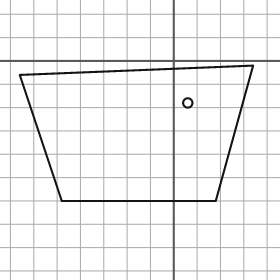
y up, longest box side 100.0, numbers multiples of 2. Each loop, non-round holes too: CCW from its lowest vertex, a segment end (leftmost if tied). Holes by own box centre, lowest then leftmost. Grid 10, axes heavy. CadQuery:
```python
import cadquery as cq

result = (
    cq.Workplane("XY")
    .moveTo(-48.0, -60.0)
    .lineTo(18.0, -60.0)
    .lineTo(34.0, -2.0)
    .lineTo(-66.0, -6.0)
    .close()
    .moveTo(6.0, -18.0)
    .circle(2.0)
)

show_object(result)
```